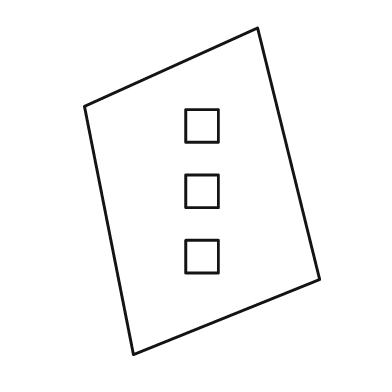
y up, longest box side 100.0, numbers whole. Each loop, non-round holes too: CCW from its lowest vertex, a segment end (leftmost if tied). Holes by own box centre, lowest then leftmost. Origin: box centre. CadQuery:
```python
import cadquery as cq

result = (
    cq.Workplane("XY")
    .moveTo(-21.0, -50.0)
    .lineTo(36.0, -27.0)
    .lineTo(17.0, 50.0)
    .lineTo(-36.0, 26.0)
    .close()
    .moveTo(-5.0, -25.0)
    .lineTo(5.0, -25.0)
    .lineTo(5.0, -15.0)
    .lineTo(-5.0, -15.0)
    .close()
    .moveTo(-5.0, -5.0)
    .lineTo(5.0, -5.0)
    .lineTo(5.0, 5.0)
    .lineTo(-5.0, 5.0)
    .close()
    .moveTo(-5.0, 15.0)
    .lineTo(5.0, 15.0)
    .lineTo(5.0, 25.0)
    .lineTo(-5.0, 25.0)
    .close()
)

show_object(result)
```